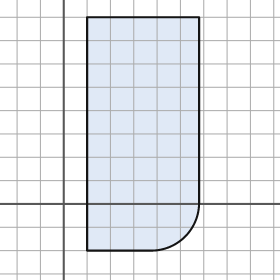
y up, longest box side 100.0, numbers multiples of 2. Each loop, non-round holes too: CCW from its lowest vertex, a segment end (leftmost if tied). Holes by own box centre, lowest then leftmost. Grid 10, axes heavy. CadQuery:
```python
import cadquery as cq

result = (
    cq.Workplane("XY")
    .moveTo(10.0, -20.0)
    .lineTo(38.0, -20.0)
    .threePointArc((52.0, -14.0), (58.0, 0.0))
    .lineTo(58.0, 80.0)
    .lineTo(10.0, 80.0)
    .close()
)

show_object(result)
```